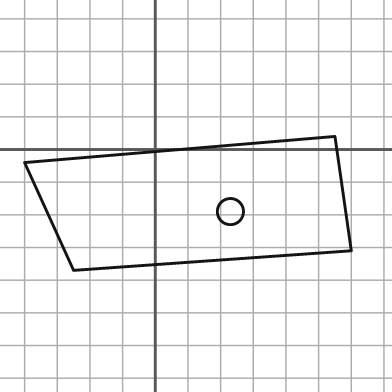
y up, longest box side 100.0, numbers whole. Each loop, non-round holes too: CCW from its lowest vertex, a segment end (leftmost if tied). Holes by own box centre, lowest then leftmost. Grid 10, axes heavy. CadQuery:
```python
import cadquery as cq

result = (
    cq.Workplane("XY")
    .moveTo(-25.0, -37.0)
    .lineTo(60.0, -31.0)
    .lineTo(55.0, 4.0)
    .lineTo(-40.0, -4.0)
    .close()
    .moveTo(23.0, -19.0)
    .circle(4.0)
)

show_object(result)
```